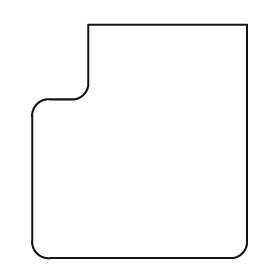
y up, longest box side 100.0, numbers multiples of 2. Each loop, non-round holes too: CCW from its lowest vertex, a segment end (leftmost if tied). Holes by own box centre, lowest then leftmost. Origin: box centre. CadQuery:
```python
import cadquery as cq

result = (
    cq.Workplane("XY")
    .moveTo(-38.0, -50.0)
    .lineTo(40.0, -50.0)
    .threePointArc((44.0, -48.0), (46.0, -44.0))
    .lineTo(46.0, 50.0)
    .lineTo(-22.0, 50.0)
    .lineTo(-22.0, 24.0)
    .threePointArc((-24.0, 20.0), (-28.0, 18.0))
    .lineTo(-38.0, 18.0)
    .threePointArc((-44.0, 16.0), (-46.0, 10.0))
    .lineTo(-46.0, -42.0)
    .threePointArc((-44.0, -48.0), (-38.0, -50.0))
    .close()
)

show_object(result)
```